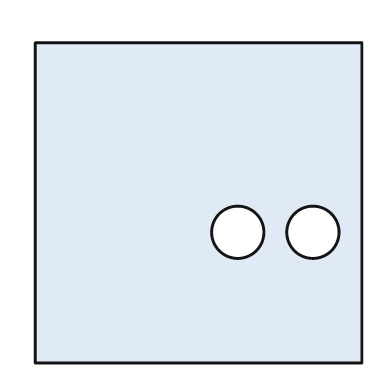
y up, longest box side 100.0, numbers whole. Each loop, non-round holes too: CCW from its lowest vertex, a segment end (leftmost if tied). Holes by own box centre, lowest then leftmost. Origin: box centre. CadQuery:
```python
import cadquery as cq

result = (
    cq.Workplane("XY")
    .moveTo(-50.0, -49.0)
    .lineTo(50.0, -49.0)
    .lineTo(50.0, 49.0)
    .lineTo(-50.0, 49.0)
    .close()
    .moveTo(12.0, -9.0)
    .circle(8.0)
    .moveTo(35.0, -9.0)
    .circle(8.0)
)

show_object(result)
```